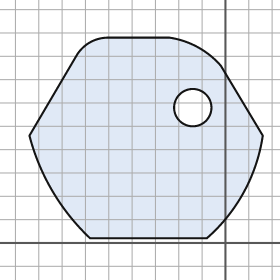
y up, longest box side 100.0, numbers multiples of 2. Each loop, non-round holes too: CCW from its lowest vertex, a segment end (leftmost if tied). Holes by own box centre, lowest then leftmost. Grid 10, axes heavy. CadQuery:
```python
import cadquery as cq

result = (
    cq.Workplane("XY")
    .moveTo(-58.0, 2.0)
    .lineTo(-8.0, 2.0)
    .threePointArc((8.0, 22.0), (16.0, 46.0))
    .lineTo(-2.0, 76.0)
    .threePointArc((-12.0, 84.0), (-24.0, 88.0))
    .lineTo(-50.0, 88.0)
    .threePointArc((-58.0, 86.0), (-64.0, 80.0))
    .lineTo(-84.0, 46.0)
    .threePointArc((-74.0, 22.0), (-58.0, 2.0))
    .close()
    .moveTo(-14.0, 58.0)
    .circle(8.0)
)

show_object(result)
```